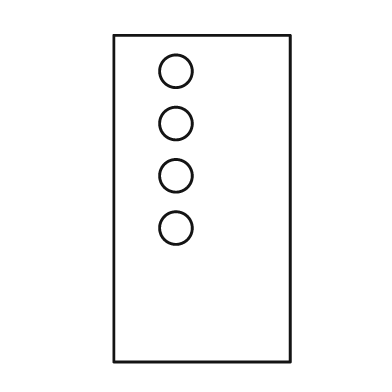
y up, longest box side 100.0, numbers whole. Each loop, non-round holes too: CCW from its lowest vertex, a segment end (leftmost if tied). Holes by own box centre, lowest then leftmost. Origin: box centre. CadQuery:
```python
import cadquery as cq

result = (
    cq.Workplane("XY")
    .moveTo(-27.0, -50.0)
    .lineTo(27.0, -50.0)
    .lineTo(27.0, 50.0)
    .lineTo(-27.0, 50.0)
    .close()
    .moveTo(-8.0, -9.0)
    .circle(5.0)
    .moveTo(-8.0, 7.0)
    .circle(5.0)
    .moveTo(-8.0, 23.0)
    .circle(5.0)
    .moveTo(-8.0, 39.0)
    .circle(5.0)
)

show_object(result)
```